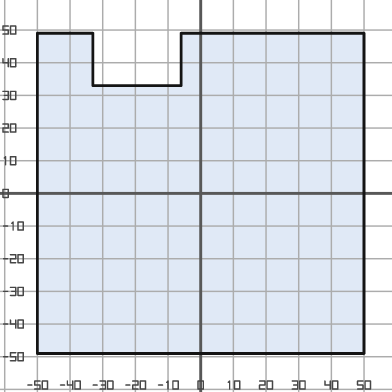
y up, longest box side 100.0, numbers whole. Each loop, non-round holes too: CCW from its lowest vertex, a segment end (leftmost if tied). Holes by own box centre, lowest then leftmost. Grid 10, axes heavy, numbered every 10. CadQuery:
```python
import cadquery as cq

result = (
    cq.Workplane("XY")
    .moveTo(-50.0, -49.0)
    .lineTo(50.0, -49.0)
    .lineTo(50.0, 49.0)
    .lineTo(-6.0, 49.0)
    .lineTo(-6.0, 33.0)
    .lineTo(-33.0, 33.0)
    .lineTo(-33.0, 49.0)
    .lineTo(-50.0, 49.0)
    .close()
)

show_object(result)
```